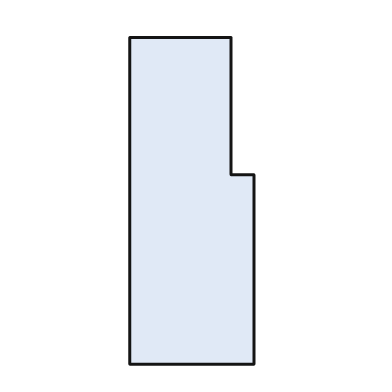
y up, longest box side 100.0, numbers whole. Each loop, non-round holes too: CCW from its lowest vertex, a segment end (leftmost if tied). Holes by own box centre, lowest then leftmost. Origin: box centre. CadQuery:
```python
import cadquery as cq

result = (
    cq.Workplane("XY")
    .moveTo(-19.0, -50.0)
    .lineTo(19.0, -50.0)
    .lineTo(19.0, 8.0)
    .lineTo(12.0, 8.0)
    .lineTo(12.0, 50.0)
    .lineTo(-19.0, 50.0)
    .close()
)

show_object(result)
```